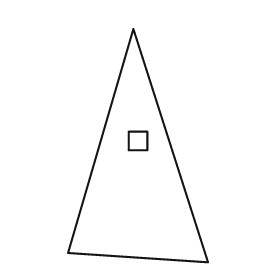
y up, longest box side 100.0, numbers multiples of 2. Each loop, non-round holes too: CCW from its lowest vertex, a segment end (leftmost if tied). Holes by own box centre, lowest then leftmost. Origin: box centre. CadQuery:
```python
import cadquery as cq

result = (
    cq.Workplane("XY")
    .moveTo(30.0, -50.0)
    .lineTo(-2.0, 50.0)
    .lineTo(-30.0, -46.0)
    .close()
    .moveTo(-4.0, -2.0)
    .lineTo(4.0, -2.0)
    .lineTo(4.0, 6.0)
    .lineTo(-4.0, 6.0)
    .close()
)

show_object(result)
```